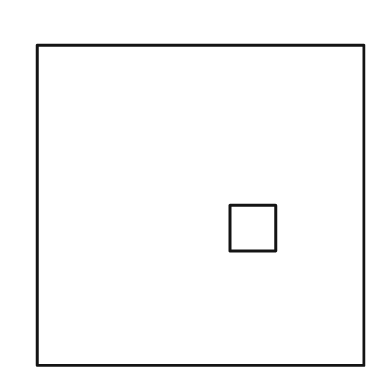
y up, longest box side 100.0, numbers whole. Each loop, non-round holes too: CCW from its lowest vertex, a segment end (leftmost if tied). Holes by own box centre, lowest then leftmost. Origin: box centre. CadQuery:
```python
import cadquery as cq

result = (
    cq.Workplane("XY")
    .moveTo(-50.0, -49.0)
    .lineTo(50.0, -49.0)
    .lineTo(50.0, 49.0)
    .lineTo(-50.0, 49.0)
    .close()
    .moveTo(9.0, -14.0)
    .lineTo(23.0, -14.0)
    .lineTo(23.0, 0.0)
    .lineTo(9.0, 0.0)
    .close()
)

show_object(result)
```